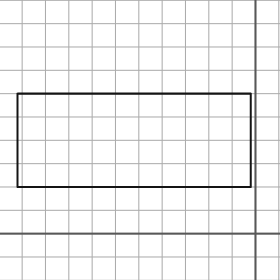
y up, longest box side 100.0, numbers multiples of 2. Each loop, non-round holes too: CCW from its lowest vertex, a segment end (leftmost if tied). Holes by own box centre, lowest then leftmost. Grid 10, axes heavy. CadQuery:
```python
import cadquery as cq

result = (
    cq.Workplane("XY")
    .moveTo(-102.0, 20.0)
    .lineTo(-2.0, 20.0)
    .lineTo(-2.0, 60.0)
    .lineTo(-102.0, 60.0)
    .close()
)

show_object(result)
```